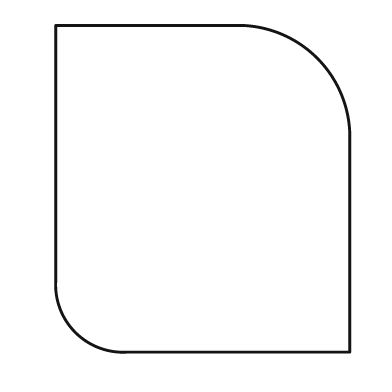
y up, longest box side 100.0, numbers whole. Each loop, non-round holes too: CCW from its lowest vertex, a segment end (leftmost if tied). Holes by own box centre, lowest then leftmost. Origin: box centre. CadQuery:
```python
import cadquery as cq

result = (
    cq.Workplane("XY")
    .moveTo(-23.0, -50.0)
    .lineTo(45.0, -50.0)
    .lineTo(45.0, 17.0)
    .threePointArc((35.0, 40.0), (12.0, 50.0))
    .lineTo(-45.0, 50.0)
    .lineTo(-45.0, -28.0)
    .threePointArc((-39.0, -44.0), (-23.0, -50.0))
    .close()
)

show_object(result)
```